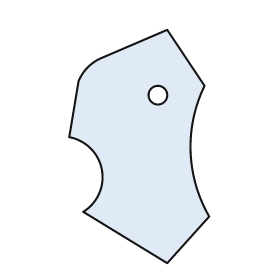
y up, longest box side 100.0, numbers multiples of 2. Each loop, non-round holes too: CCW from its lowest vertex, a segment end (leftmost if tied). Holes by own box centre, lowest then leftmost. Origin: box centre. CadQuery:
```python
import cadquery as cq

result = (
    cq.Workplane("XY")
    .moveTo(12.0, -50.0)
    .lineTo(30.0, -30.0)
    .threePointArc((22.0, -2.0), (28.0, 26.0))
    .lineTo(12.0, 50.0)
    .lineTo(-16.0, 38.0)
    .threePointArc((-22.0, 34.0), (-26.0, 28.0))
    .lineTo(-30.0, 4.0)
    .threePointArc((-16.0, -10.0), (-24.0, -28.0))
    .close()
    .moveTo(8.0, 22.0)
    .circle(4.0)
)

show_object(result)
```